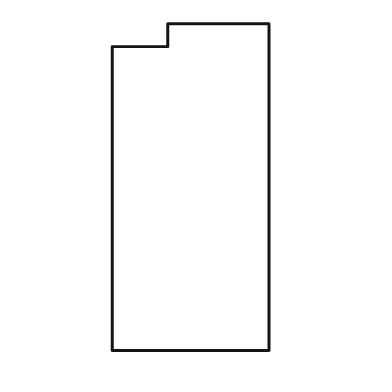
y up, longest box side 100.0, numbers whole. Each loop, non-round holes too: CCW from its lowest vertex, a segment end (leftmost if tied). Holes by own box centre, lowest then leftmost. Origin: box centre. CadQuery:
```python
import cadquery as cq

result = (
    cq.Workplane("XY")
    .moveTo(-24.0, -50.0)
    .lineTo(24.0, -50.0)
    .lineTo(24.0, 50.0)
    .lineTo(-7.0, 50.0)
    .lineTo(-7.0, 43.0)
    .lineTo(-24.0, 43.0)
    .close()
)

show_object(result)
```